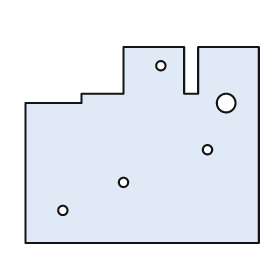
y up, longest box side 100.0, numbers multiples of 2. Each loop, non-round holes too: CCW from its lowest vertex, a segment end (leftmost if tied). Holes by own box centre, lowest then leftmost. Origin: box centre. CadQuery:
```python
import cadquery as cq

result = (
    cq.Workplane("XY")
    .moveTo(-50.0, -42.0)
    .lineTo(50.0, -42.0)
    .lineTo(50.0, 42.0)
    .lineTo(24.0, 42.0)
    .lineTo(24.0, 22.0)
    .lineTo(18.0, 22.0)
    .lineTo(18.0, 42.0)
    .lineTo(-8.0, 42.0)
    .lineTo(-8.0, 22.0)
    .lineTo(-26.0, 22.0)
    .lineTo(-26.0, 18.0)
    .lineTo(-50.0, 18.0)
    .close()
    .moveTo(-34.0, -28.0)
    .circle(2.0)
    .moveTo(-8.0, -16.0)
    .circle(2.0)
    .moveTo(28.0, -2.0)
    .circle(2.0)
    .moveTo(36.0, 18.0)
    .circle(4.0)
    .moveTo(8.0, 34.0)
    .circle(2.0)
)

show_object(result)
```